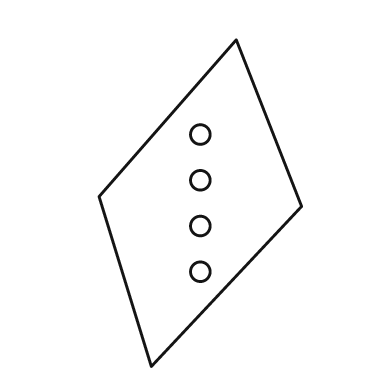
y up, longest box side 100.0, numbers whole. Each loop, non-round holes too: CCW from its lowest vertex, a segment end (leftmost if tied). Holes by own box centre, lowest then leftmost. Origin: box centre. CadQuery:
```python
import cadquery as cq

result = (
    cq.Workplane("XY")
    .moveTo(-15.0, -50.0)
    .lineTo(31.0, -1.0)
    .lineTo(11.0, 50.0)
    .lineTo(-31.0, 2.0)
    .close()
    .moveTo(0.0, -21.0)
    .circle(3.0)
    .moveTo(0.0, -7.0)
    .circle(3.0)
    .moveTo(0.0, 7.0)
    .circle(3.0)
    .moveTo(0.0, 21.0)
    .circle(3.0)
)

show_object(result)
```